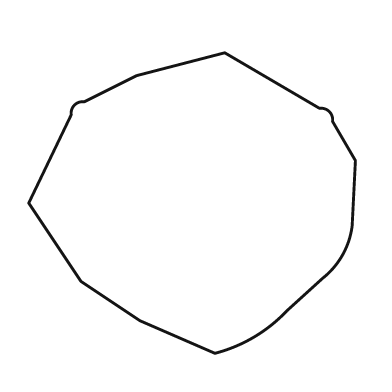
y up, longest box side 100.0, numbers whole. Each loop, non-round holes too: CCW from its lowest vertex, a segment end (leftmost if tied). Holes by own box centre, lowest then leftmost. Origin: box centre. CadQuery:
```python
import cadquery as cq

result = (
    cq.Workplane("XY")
    .moveTo(7.0, -46.0)
    .threePointArc((19.0, -41.0), (29.0, -33.0))
    .lineTo(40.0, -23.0)
    .threePointArc((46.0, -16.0), (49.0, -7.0))
    .lineTo(50.0, 13.0)
    .lineTo(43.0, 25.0)
    .threePointArc((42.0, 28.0), (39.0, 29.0))
    .lineTo(10.0, 46.0)
    .lineTo(-17.0, 39.0)
    .lineTo(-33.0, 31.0)
    .threePointArc((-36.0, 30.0), (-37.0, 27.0))
    .lineTo(-50.0, 0.0)
    .lineTo(-34.0, -24.0)
    .lineTo(-16.0, -36.0)
    .close()
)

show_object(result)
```